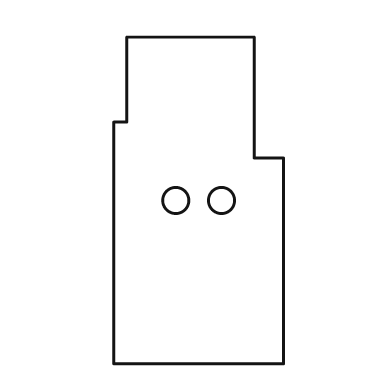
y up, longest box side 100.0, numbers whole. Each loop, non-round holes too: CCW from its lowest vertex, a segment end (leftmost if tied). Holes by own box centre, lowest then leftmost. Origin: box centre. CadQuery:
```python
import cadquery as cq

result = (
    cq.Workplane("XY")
    .moveTo(-26.0, -50.0)
    .lineTo(26.0, -50.0)
    .lineTo(26.0, 13.0)
    .lineTo(17.0, 13.0)
    .lineTo(17.0, 50.0)
    .lineTo(-22.0, 50.0)
    .lineTo(-22.0, 24.0)
    .lineTo(-26.0, 24.0)
    .close()
    .moveTo(-7.0, 0.0)
    .circle(4.0)
    .moveTo(7.0, 0.0)
    .circle(4.0)
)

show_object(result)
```